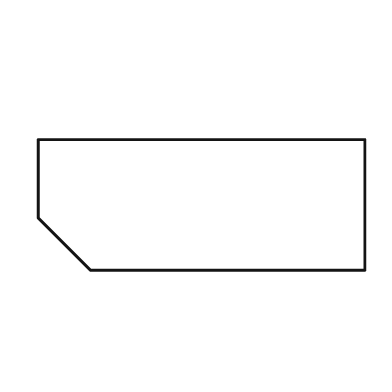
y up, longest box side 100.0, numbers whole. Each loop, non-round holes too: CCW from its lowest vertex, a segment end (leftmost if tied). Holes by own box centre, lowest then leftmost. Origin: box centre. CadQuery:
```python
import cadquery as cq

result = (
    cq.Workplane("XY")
    .moveTo(-34.0, -20.0)
    .lineTo(50.0, -20.0)
    .lineTo(50.0, 20.0)
    .lineTo(-50.0, 20.0)
    .lineTo(-50.0, -4.0)
    .close()
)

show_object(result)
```